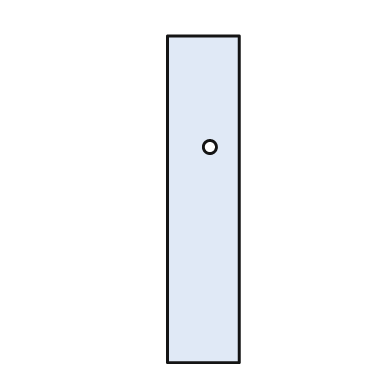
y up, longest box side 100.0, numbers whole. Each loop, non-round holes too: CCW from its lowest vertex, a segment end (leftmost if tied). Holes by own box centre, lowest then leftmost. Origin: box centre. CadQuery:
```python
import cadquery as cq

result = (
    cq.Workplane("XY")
    .moveTo(-11.0, -50.0)
    .lineTo(11.0, -50.0)
    .lineTo(11.0, 50.0)
    .lineTo(-11.0, 50.0)
    .close()
    .moveTo(2.0, 16.0)
    .circle(2.0)
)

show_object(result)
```